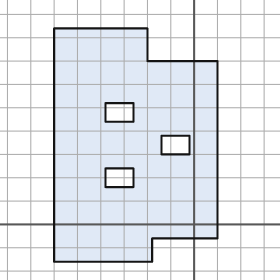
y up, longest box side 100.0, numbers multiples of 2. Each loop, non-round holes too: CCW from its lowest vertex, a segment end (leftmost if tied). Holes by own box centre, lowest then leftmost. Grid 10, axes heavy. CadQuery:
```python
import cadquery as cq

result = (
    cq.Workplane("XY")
    .moveTo(-60.0, -16.0)
    .lineTo(-18.0, -16.0)
    .lineTo(-18.0, -6.0)
    .lineTo(10.0, -6.0)
    .lineTo(10.0, 70.0)
    .lineTo(-20.0, 70.0)
    .lineTo(-20.0, 84.0)
    .lineTo(-60.0, 84.0)
    .close()
    .moveTo(-38.0, 16.0)
    .lineTo(-26.0, 16.0)
    .lineTo(-26.0, 24.0)
    .lineTo(-38.0, 24.0)
    .close()
    .moveTo(-14.0, 30.0)
    .lineTo(-2.0, 30.0)
    .lineTo(-2.0, 38.0)
    .lineTo(-14.0, 38.0)
    .close()
    .moveTo(-38.0, 44.0)
    .lineTo(-26.0, 44.0)
    .lineTo(-26.0, 52.0)
    .lineTo(-38.0, 52.0)
    .close()
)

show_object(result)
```